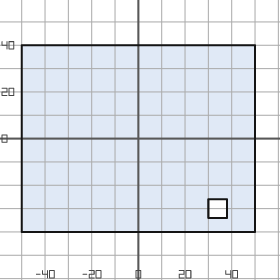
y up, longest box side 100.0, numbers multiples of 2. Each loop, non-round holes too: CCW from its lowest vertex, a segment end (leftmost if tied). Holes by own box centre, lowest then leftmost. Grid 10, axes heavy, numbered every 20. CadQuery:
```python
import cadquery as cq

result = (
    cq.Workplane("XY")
    .moveTo(-50.0, -40.0)
    .lineTo(50.0, -40.0)
    .lineTo(50.0, 40.0)
    .lineTo(-50.0, 40.0)
    .close()
    .moveTo(30.0, -34.0)
    .lineTo(38.0, -34.0)
    .lineTo(38.0, -26.0)
    .lineTo(30.0, -26.0)
    .close()
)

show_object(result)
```